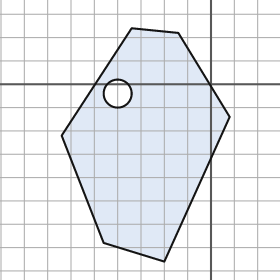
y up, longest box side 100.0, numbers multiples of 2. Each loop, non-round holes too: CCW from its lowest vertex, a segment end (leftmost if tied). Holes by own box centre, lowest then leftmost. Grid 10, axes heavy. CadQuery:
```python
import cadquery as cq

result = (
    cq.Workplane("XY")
    .moveTo(-20.0, -76.0)
    .lineTo(8.0, -14.0)
    .lineTo(-14.0, 22.0)
    .lineTo(-34.0, 24.0)
    .lineTo(-64.0, -22.0)
    .lineTo(-46.0, -68.0)
    .close()
    .moveTo(-40.0, -4.0)
    .circle(6.0)
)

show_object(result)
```